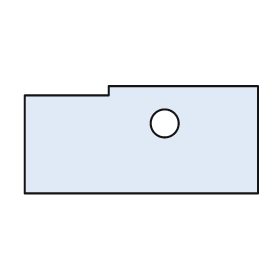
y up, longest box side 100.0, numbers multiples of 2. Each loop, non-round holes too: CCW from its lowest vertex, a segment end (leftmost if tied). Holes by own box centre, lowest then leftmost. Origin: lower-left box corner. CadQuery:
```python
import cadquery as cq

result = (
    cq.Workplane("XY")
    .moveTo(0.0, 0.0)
    .lineTo(100.0, 0.0)
    .lineTo(100.0, 46.0)
    .lineTo(36.0, 46.0)
    .lineTo(36.0, 42.0)
    .lineTo(0.0, 42.0)
    .close()
    .moveTo(60.0, 30.0)
    .circle(6.0)
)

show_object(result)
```